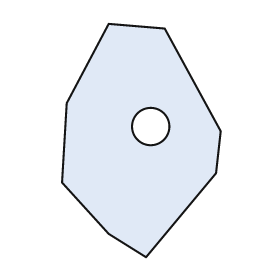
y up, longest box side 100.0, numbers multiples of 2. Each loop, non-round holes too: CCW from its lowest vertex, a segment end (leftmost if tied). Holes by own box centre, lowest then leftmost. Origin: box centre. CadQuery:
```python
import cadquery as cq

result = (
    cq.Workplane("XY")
    .moveTo(2.0, -50.0)
    .lineTo(32.0, -14.0)
    .lineTo(34.0, 4.0)
    .lineTo(10.0, 48.0)
    .lineTo(-14.0, 50.0)
    .lineTo(-32.0, 16.0)
    .lineTo(-34.0, -18.0)
    .lineTo(-14.0, -40.0)
    .close()
    .moveTo(4.0, 6.0)
    .circle(8.0)
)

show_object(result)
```